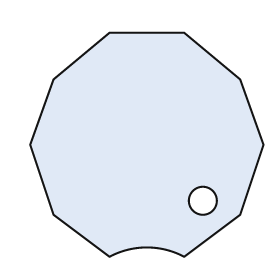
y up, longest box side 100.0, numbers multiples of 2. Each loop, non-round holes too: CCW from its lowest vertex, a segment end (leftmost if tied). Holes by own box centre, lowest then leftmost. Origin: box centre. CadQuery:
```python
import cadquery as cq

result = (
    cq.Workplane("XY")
    .moveTo(-16.0, -48.0)
    .threePointArc((0.0, -44.0), (16.0, -48.0))
    .lineTo(40.0, -30.0)
    .lineTo(50.0, 0.0)
    .lineTo(40.0, 28.0)
    .lineTo(16.0, 48.0)
    .lineTo(-16.0, 48.0)
    .lineTo(-40.0, 28.0)
    .lineTo(-50.0, 0.0)
    .lineTo(-40.0, -30.0)
    .close()
    .moveTo(24.0, -24.0)
    .circle(6.0)
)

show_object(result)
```